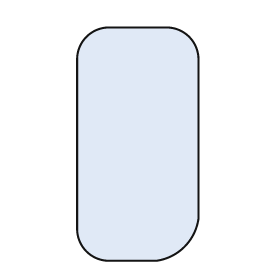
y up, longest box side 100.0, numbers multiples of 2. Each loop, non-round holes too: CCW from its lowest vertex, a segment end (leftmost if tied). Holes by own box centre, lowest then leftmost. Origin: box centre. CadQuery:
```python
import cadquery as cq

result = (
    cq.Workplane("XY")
    .moveTo(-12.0, -50.0)
    .lineTo(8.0, -50.0)
    .threePointArc((20.0, -44.0), (26.0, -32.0))
    .lineTo(26.0, 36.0)
    .threePointArc((22.0, 46.0), (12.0, 50.0))
    .lineTo(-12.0, 50.0)
    .threePointArc((-22.0, 46.0), (-26.0, 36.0))
    .lineTo(-26.0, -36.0)
    .threePointArc((-22.0, -46.0), (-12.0, -50.0))
    .close()
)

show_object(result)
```